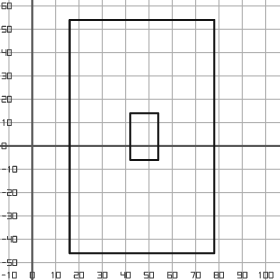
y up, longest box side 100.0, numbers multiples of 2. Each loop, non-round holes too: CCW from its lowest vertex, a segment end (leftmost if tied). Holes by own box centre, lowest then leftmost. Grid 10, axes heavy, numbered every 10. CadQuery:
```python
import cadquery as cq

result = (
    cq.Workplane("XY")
    .moveTo(16.0, -46.0)
    .lineTo(78.0, -46.0)
    .lineTo(78.0, 54.0)
    .lineTo(16.0, 54.0)
    .close()
    .moveTo(42.0, -6.0)
    .lineTo(54.0, -6.0)
    .lineTo(54.0, 14.0)
    .lineTo(42.0, 14.0)
    .close()
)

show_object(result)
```